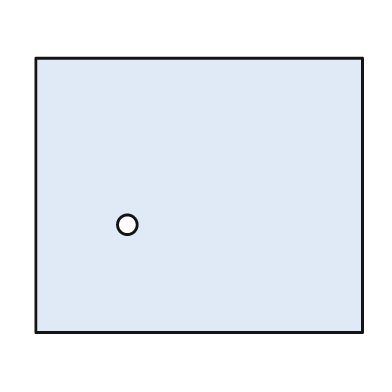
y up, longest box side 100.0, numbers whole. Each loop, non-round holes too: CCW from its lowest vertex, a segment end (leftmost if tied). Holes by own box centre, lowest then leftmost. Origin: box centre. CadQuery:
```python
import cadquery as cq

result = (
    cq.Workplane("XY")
    .moveTo(-50.0, -42.0)
    .lineTo(50.0, -42.0)
    .lineTo(50.0, 42.0)
    .lineTo(-50.0, 42.0)
    .close()
    .moveTo(-22.0, -9.0)
    .circle(3.0)
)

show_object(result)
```